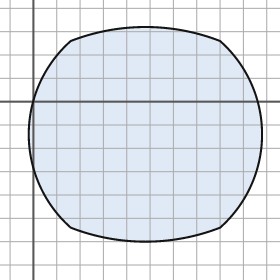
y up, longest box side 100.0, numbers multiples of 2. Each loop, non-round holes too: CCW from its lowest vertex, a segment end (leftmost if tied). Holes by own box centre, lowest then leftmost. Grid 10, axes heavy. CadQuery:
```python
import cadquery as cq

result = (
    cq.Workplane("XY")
    .moveTo(16.0, -54.0)
    .threePointArc((48.0, -60.0), (80.0, -54.0))
    .threePointArc((98.0, -14.0), (80.0, 26.0))
    .threePointArc((48.0, 32.0), (16.0, 26.0))
    .threePointArc((-2.0, -14.0), (16.0, -54.0))
    .close()
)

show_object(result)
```